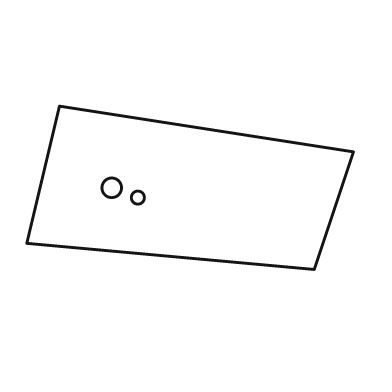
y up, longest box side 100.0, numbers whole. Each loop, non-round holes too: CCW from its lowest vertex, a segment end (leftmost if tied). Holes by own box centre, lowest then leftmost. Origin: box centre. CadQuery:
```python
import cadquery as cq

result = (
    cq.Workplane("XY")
    .moveTo(38.0, -25.0)
    .lineTo(50.0, 11.0)
    .lineTo(-40.0, 25.0)
    .lineTo(-50.0, -17.0)
    .close()
    .moveTo(-16.0, -3.0)
    .circle(2.0)
    .moveTo(-24.0, 0.0)
    .circle(3.0)
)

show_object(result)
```